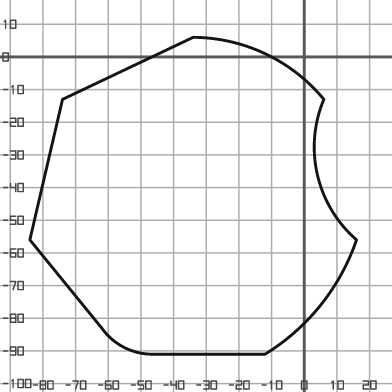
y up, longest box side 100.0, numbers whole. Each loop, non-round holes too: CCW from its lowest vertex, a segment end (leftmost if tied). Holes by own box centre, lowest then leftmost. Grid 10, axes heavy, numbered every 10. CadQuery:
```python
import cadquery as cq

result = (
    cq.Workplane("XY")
    .moveTo(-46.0, -91.0)
    .lineTo(-12.0, -91.0)
    .threePointArc((5.0, -76.0), (16.0, -56.0))
    .threePointArc((4.0, -36.0), (6.0, -13.0))
    .threePointArc((-12.0, 1.0), (-34.0, 6.0))
    .lineTo(-74.0, -13.0)
    .lineTo(-84.0, -56.0)
    .lineTo(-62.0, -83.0)
    .threePointArc((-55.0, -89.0), (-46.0, -91.0))
    .close()
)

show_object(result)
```